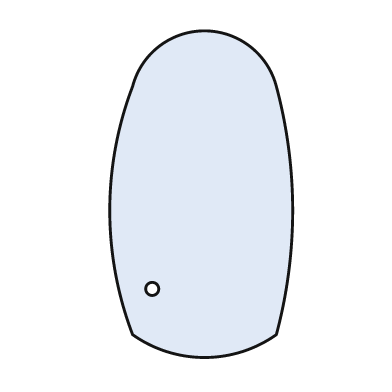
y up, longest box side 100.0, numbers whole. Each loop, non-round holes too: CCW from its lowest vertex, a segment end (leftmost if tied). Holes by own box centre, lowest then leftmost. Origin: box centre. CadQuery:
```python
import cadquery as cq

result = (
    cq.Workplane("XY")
    .moveTo(-21.0, -43.0)
    .threePointArc((1.0, -50.0), (23.0, -43.0))
    .threePointArc((28.0, -5.0), (23.0, 33.0))
    .threePointArc((1.0, 50.0), (-21.0, 33.0))
    .threePointArc((-28.0, -5.0), (-21.0, -43.0))
    .close()
    .moveTo(-15.0, -29.0)
    .circle(2.0)
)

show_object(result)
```